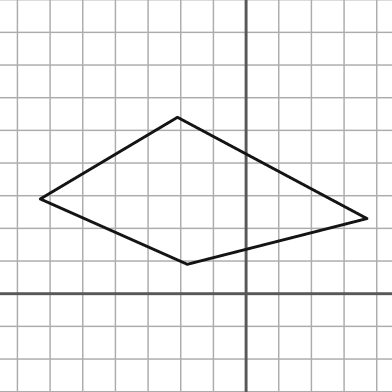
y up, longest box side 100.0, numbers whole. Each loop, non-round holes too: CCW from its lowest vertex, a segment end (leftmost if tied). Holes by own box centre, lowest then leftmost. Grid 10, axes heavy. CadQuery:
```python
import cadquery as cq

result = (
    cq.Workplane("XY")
    .moveTo(-18.0, 9.0)
    .lineTo(37.0, 23.0)
    .lineTo(-21.0, 54.0)
    .lineTo(-63.0, 29.0)
    .close()
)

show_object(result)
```